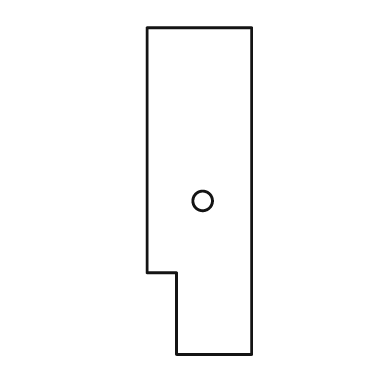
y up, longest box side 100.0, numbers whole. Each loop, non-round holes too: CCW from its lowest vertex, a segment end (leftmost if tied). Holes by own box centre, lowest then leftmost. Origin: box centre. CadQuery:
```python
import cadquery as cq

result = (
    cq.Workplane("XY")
    .moveTo(-7.0, -50.0)
    .lineTo(16.0, -50.0)
    .lineTo(16.0, 50.0)
    .lineTo(-16.0, 50.0)
    .lineTo(-16.0, -25.0)
    .lineTo(-7.0, -25.0)
    .close()
    .moveTo(1.0, -3.0)
    .circle(3.0)
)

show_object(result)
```